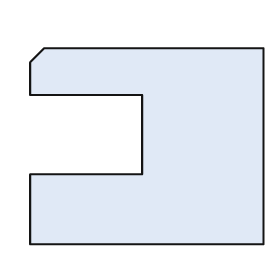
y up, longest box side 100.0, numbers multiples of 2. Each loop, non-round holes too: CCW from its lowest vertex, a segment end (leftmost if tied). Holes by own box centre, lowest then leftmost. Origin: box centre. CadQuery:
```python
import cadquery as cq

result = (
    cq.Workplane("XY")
    .moveTo(-50.0, -42.0)
    .lineTo(50.0, -42.0)
    .lineTo(50.0, 42.0)
    .lineTo(-44.0, 42.0)
    .lineTo(-50.0, 36.0)
    .lineTo(-50.0, 22.0)
    .lineTo(-2.0, 22.0)
    .lineTo(-2.0, -12.0)
    .lineTo(-50.0, -12.0)
    .close()
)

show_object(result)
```